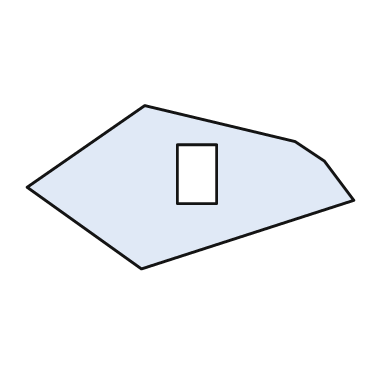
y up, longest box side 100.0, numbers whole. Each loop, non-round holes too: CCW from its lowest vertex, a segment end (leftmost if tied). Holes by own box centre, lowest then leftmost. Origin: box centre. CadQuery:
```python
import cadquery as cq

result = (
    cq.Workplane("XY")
    .moveTo(-15.0, -25.0)
    .lineTo(50.0, -4.0)
    .lineTo(41.0, 8.0)
    .lineTo(32.0, 14.0)
    .lineTo(-14.0, 25.0)
    .lineTo(-50.0, 0.0)
    .close()
    .moveTo(-4.0, -5.0)
    .lineTo(8.0, -5.0)
    .lineTo(8.0, 13.0)
    .lineTo(-4.0, 13.0)
    .close()
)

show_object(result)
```